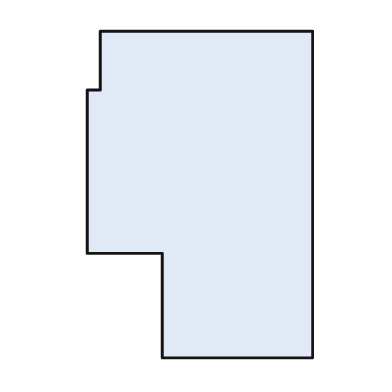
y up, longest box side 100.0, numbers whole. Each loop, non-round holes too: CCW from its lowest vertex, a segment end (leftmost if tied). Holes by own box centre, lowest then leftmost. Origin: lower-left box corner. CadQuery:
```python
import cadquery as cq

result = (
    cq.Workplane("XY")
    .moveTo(23.0, 0.0)
    .lineTo(69.0, 0.0)
    .lineTo(69.0, 100.0)
    .lineTo(4.0, 100.0)
    .lineTo(4.0, 82.0)
    .lineTo(0.0, 82.0)
    .lineTo(0.0, 32.0)
    .lineTo(23.0, 32.0)
    .close()
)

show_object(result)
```